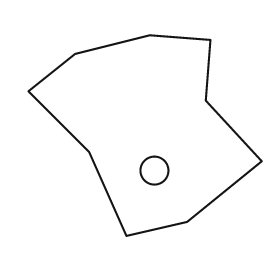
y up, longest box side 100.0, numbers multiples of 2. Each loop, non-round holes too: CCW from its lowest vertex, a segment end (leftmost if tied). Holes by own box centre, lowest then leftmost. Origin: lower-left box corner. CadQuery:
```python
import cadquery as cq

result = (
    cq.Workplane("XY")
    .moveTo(42.0, 0.0)
    .lineTo(68.0, 6.0)
    .lineTo(100.0, 32.0)
    .lineTo(76.0, 58.0)
    .lineTo(78.0, 84.0)
    .lineTo(52.0, 86.0)
    .lineTo(20.0, 78.0)
    .lineTo(0.0, 62.0)
    .lineTo(26.0, 36.0)
    .close()
    .moveTo(54.0, 28.0)
    .circle(6.0)
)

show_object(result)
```